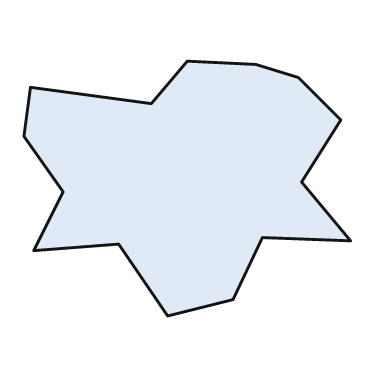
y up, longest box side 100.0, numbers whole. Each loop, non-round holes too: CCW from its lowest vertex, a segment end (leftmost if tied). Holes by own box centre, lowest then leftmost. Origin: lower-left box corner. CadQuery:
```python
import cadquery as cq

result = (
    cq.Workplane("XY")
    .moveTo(44.0, 0.0)
    .lineTo(64.0, 5.0)
    .lineTo(73.0, 24.0)
    .lineTo(100.0, 23.0)
    .lineTo(85.0, 41.0)
    .lineTo(97.0, 60.0)
    .lineTo(84.0, 73.0)
    .lineTo(71.0, 77.0)
    .lineTo(50.0, 78.0)
    .lineTo(39.0, 65.0)
    .lineTo(2.0, 70.0)
    .lineTo(0.0, 55.0)
    .lineTo(12.0, 38.0)
    .lineTo(3.0, 20.0)
    .lineTo(29.0, 22.0)
    .close()
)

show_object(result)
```